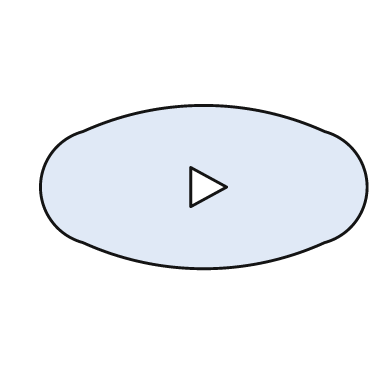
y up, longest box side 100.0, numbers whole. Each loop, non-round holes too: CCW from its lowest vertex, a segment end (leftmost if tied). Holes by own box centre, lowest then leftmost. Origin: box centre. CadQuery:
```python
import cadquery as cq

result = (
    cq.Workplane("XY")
    .moveTo(-37.0, -17.0)
    .threePointArc((0.0, -25.0), (37.0, -17.0))
    .threePointArc((50.0, 0.0), (37.0, 17.0))
    .threePointArc((0.0, 25.0), (-37.0, 17.0))
    .threePointArc((-50.0, 0.0), (-37.0, -17.0))
    .close()
    .moveTo(-4.0, -6.0)
    .lineTo(7.0, 0.0)
    .lineTo(-4.0, 6.0)
    .close()
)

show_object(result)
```